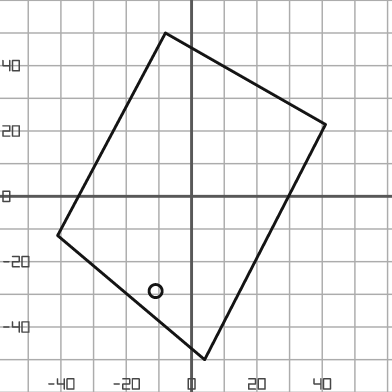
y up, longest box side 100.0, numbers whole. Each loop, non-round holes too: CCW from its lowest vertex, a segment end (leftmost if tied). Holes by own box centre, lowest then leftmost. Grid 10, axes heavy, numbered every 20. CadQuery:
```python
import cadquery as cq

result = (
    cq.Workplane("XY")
    .moveTo(4.0, -50.0)
    .lineTo(41.0, 22.0)
    .lineTo(-8.0, 50.0)
    .lineTo(-41.0, -12.0)
    .close()
    .moveTo(-11.0, -29.0)
    .circle(2.0)
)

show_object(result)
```